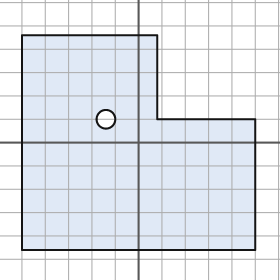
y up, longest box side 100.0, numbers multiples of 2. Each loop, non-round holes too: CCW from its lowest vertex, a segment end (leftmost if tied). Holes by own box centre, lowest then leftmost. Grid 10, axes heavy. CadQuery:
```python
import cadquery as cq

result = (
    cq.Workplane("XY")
    .moveTo(-50.0, -46.0)
    .lineTo(50.0, -46.0)
    .lineTo(50.0, 10.0)
    .lineTo(8.0, 10.0)
    .lineTo(8.0, 46.0)
    .lineTo(-50.0, 46.0)
    .close()
    .moveTo(-14.0, 10.0)
    .circle(4.0)
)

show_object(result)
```